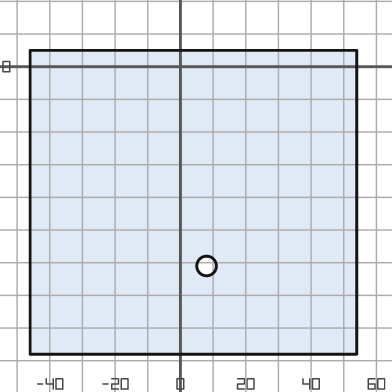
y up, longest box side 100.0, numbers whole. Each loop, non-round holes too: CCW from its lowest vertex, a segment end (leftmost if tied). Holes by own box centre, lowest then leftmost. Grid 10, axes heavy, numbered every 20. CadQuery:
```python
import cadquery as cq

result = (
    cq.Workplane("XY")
    .moveTo(-46.0, -88.0)
    .lineTo(54.0, -88.0)
    .lineTo(54.0, 5.0)
    .lineTo(-46.0, 5.0)
    .close()
    .moveTo(8.0, -61.0)
    .circle(3.0)
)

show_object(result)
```